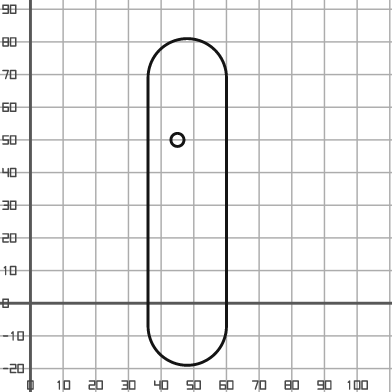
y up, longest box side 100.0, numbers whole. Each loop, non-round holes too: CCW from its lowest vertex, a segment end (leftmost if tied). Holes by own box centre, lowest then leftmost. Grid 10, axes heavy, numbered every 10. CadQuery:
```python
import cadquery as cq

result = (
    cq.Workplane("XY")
    .moveTo(36.0, -7.0)
    .threePointArc((48.0, -19.0), (60.0, -7.0))
    .lineTo(60.0, 69.0)
    .threePointArc((48.0, 81.0), (36.0, 69.0))
    .close()
    .moveTo(45.0, 50.0)
    .circle(2.0)
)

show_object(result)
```